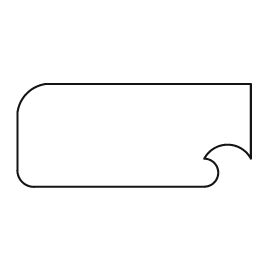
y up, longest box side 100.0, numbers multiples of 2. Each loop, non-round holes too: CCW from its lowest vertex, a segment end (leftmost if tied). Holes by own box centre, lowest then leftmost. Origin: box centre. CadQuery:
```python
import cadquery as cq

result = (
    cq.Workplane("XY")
    .moveTo(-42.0, -22.0)
    .lineTo(30.0, -22.0)
    .threePointArc((36.0, -16.0), (30.0, -10.0))
    .threePointArc((40.0, -4.0), (50.0, -10.0))
    .lineTo(50.0, 22.0)
    .lineTo(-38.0, 22.0)
    .threePointArc((-46.0, 18.0), (-50.0, 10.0))
    .lineTo(-50.0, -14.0)
    .threePointArc((-48.0, -20.0), (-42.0, -22.0))
    .close()
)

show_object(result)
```